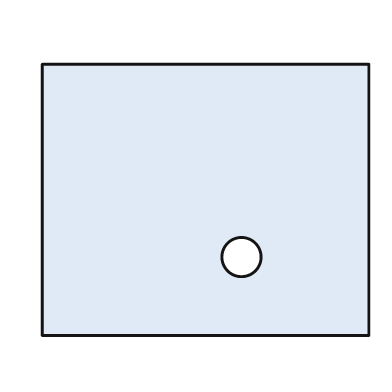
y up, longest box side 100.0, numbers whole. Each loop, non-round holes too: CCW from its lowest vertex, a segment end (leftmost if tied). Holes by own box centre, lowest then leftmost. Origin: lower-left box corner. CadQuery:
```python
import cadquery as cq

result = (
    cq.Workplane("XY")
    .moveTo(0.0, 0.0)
    .lineTo(100.0, 0.0)
    .lineTo(100.0, 83.0)
    .lineTo(0.0, 83.0)
    .close()
    .moveTo(61.0, 24.0)
    .circle(6.0)
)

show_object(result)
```